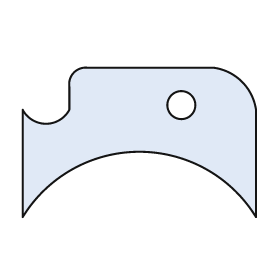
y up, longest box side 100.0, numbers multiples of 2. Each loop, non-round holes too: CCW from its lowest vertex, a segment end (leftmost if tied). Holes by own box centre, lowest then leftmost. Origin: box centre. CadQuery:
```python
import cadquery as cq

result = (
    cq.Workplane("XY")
    .moveTo(-50.0, -32.0)
    .threePointArc((0.0, -4.0), (50.0, -32.0))
    .lineTo(50.0, 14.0)
    .threePointArc((44.0, 26.0), (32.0, 32.0))
    .lineTo(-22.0, 32.0)
    .threePointArc((-28.0, 30.0), (-30.0, 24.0))
    .lineTo(-30.0, 14.0)
    .threePointArc((-40.0, 8.0), (-50.0, 14.0))
    .close()
    .moveTo(18.0, 16.0)
    .circle(6.0)
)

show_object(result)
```